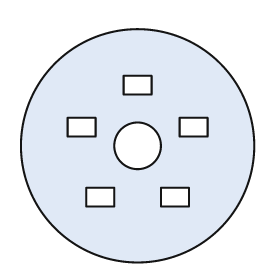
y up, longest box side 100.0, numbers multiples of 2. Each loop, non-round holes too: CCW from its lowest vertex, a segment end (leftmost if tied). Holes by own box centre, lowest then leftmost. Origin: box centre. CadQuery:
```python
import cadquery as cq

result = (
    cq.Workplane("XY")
    .moveTo(0.0, 0.0)
    .circle(50.0)
    .moveTo(-22.0, -26.0)
    .lineTo(-10.0, -26.0)
    .lineTo(-10.0, -18.0)
    .lineTo(-22.0, -18.0)
    .close()
    .moveTo(10.0, -26.0)
    .lineTo(22.0, -26.0)
    .lineTo(22.0, -18.0)
    .lineTo(10.0, -18.0)
    .close()
    .moveTo(0.0, 0.0)
    .circle(10.0)
    .moveTo(-30.0, 4.0)
    .lineTo(-18.0, 4.0)
    .lineTo(-18.0, 12.0)
    .lineTo(-30.0, 12.0)
    .close()
    .moveTo(18.0, 4.0)
    .lineTo(30.0, 4.0)
    .lineTo(30.0, 12.0)
    .lineTo(18.0, 12.0)
    .close()
    .moveTo(-6.0, 22.0)
    .lineTo(6.0, 22.0)
    .lineTo(6.0, 30.0)
    .lineTo(-6.0, 30.0)
    .close()
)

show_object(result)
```